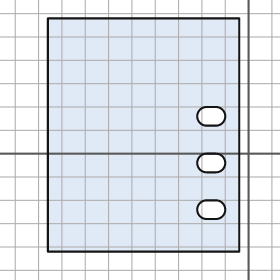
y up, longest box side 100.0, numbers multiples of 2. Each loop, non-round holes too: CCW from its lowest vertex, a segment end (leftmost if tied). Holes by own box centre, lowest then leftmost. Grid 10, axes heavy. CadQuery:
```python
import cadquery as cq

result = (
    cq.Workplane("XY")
    .moveTo(-86.0, -42.0)
    .lineTo(-4.0, -42.0)
    .lineTo(-4.0, 58.0)
    .lineTo(-86.0, 58.0)
    .close()
    .moveTo(-18.0, -28.0)
    .lineTo(-14.0, -28.0)
    .threePointArc((-10.0, -24.0), (-14.0, -20.0))
    .lineTo(-18.0, -20.0)
    .threePointArc((-22.0, -24.0), (-18.0, -28.0))
    .close()
    .moveTo(-18.0, -8.0)
    .lineTo(-14.0, -8.0)
    .threePointArc((-10.0, -4.0), (-14.0, 0.0))
    .lineTo(-18.0, 0.0)
    .threePointArc((-22.0, -4.0), (-18.0, -8.0))
    .close()
    .moveTo(-18.0, 12.0)
    .lineTo(-14.0, 12.0)
    .threePointArc((-10.0, 16.0), (-14.0, 20.0))
    .lineTo(-18.0, 20.0)
    .threePointArc((-22.0, 16.0), (-18.0, 12.0))
    .close()
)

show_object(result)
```